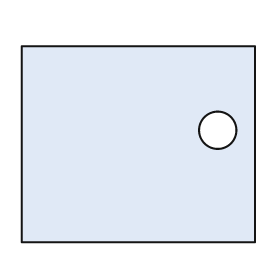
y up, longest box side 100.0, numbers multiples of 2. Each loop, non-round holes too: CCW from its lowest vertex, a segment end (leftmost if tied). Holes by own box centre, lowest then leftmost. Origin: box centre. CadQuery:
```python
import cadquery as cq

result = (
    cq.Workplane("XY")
    .moveTo(-50.0, -42.0)
    .lineTo(50.0, -42.0)
    .lineTo(50.0, 42.0)
    .lineTo(-50.0, 42.0)
    .close()
    .moveTo(34.0, 6.0)
    .circle(8.0)
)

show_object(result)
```